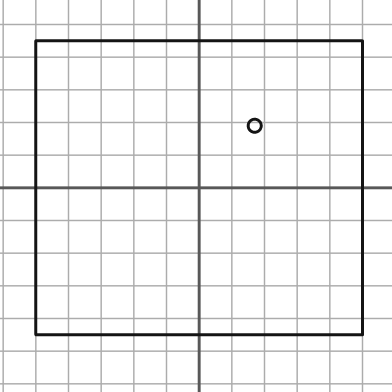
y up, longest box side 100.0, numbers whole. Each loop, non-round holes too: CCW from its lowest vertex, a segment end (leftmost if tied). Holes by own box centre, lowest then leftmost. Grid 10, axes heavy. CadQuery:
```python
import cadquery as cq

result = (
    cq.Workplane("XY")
    .moveTo(-50.0, -45.0)
    .lineTo(50.0, -45.0)
    .lineTo(50.0, 45.0)
    .lineTo(-50.0, 45.0)
    .close()
    .moveTo(17.0, 19.0)
    .circle(2.0)
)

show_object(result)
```